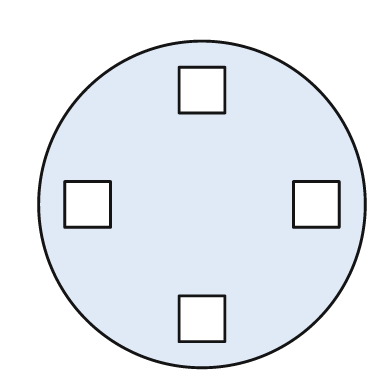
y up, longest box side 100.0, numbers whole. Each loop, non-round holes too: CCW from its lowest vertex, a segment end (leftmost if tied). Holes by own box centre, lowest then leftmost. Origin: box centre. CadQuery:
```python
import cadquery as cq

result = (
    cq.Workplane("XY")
    .moveTo(0.0, 0.0)
    .circle(50.0)
    .moveTo(-7.0, -42.0)
    .lineTo(7.0, -42.0)
    .lineTo(7.0, -28.0)
    .lineTo(-7.0, -28.0)
    .close()
    .moveTo(-42.0, -7.0)
    .lineTo(-28.0, -7.0)
    .lineTo(-28.0, 7.0)
    .lineTo(-42.0, 7.0)
    .close()
    .moveTo(28.0, -7.0)
    .lineTo(42.0, -7.0)
    .lineTo(42.0, 7.0)
    .lineTo(28.0, 7.0)
    .close()
    .moveTo(-7.0, 28.0)
    .lineTo(7.0, 28.0)
    .lineTo(7.0, 42.0)
    .lineTo(-7.0, 42.0)
    .close()
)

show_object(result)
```